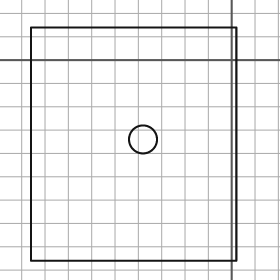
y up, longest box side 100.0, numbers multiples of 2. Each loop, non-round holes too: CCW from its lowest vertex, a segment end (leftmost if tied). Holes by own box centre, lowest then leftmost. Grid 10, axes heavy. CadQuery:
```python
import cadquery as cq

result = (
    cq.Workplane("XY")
    .moveTo(-86.0, -86.0)
    .lineTo(2.0, -86.0)
    .lineTo(2.0, 14.0)
    .lineTo(-86.0, 14.0)
    .close()
    .moveTo(-38.0, -34.0)
    .circle(6.0)
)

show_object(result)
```